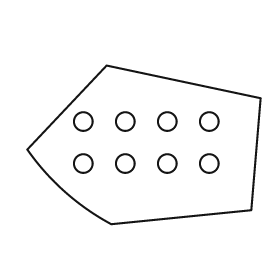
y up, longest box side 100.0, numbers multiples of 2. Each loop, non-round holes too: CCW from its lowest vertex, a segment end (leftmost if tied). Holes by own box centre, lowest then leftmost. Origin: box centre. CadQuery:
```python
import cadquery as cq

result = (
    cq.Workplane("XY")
    .moveTo(-14.0, -34.0)
    .lineTo(46.0, -28.0)
    .lineTo(50.0, 20.0)
    .lineTo(-16.0, 34.0)
    .lineTo(-50.0, -2.0)
    .threePointArc((-34.0, -20.0), (-14.0, -34.0))
    .close()
    .moveTo(-26.0, -8.0)
    .circle(4.0)
    .moveTo(-8.0, -8.0)
    .circle(4.0)
    .moveTo(10.0, -8.0)
    .circle(4.0)
    .moveTo(28.0, -8.0)
    .circle(4.0)
    .moveTo(-26.0, 10.0)
    .circle(4.0)
    .moveTo(-8.0, 10.0)
    .circle(4.0)
    .moveTo(10.0, 10.0)
    .circle(4.0)
    .moveTo(28.0, 10.0)
    .circle(4.0)
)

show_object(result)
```